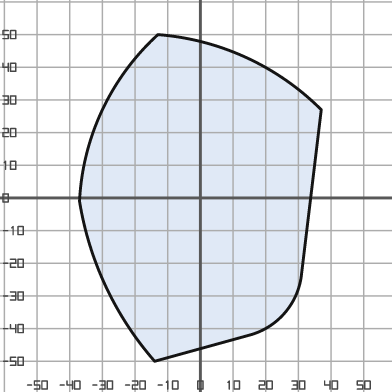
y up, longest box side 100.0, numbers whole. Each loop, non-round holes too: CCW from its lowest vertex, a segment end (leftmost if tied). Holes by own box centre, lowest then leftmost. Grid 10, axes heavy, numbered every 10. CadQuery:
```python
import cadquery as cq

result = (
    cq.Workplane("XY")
    .moveTo(-14.0, -50.0)
    .lineTo(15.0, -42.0)
    .threePointArc((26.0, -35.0), (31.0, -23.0))
    .lineTo(37.0, 27.0)
    .threePointArc((14.0, 43.0), (-13.0, 50.0))
    .threePointArc((-30.0, 27.0), (-37.0, -1.0))
    .threePointArc((-29.0, -27.0), (-14.0, -50.0))
    .close()
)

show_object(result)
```